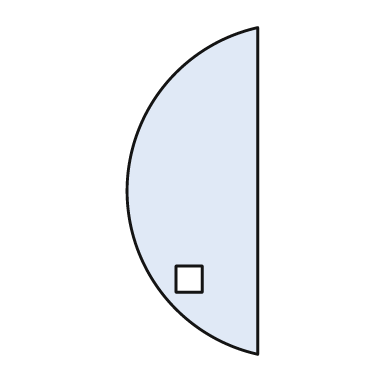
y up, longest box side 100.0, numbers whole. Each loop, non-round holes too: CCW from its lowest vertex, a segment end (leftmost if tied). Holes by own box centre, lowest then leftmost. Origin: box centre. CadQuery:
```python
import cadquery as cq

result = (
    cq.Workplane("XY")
    .moveTo(20.0, -50.0)
    .lineTo(20.0, 50.0)
    .threePointArc((-20.0, 0.0), (20.0, -50.0))
    .close()
    .moveTo(-5.0, -31.0)
    .lineTo(3.0, -31.0)
    .lineTo(3.0, -23.0)
    .lineTo(-5.0, -23.0)
    .close()
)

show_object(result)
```